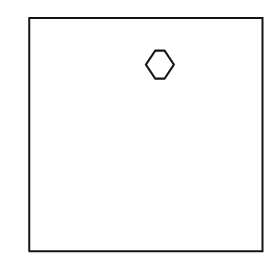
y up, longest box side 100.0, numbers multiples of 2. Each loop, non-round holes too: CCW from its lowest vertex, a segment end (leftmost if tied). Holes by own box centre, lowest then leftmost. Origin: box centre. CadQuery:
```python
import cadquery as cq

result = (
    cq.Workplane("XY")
    .moveTo(-50.0, -50.0)
    .lineTo(50.0, -50.0)
    .lineTo(50.0, 50.0)
    .lineTo(-50.0, 50.0)
    .close()
    .moveTo(4.0, 24.0)
    .lineTo(8.0, 24.0)
    .lineTo(12.0, 30.0)
    .lineTo(8.0, 36.0)
    .lineTo(4.0, 36.0)
    .lineTo(0.0, 30.0)
    .close()
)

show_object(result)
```